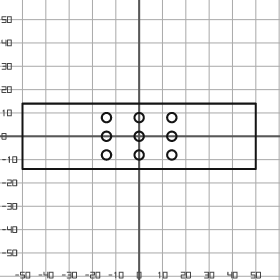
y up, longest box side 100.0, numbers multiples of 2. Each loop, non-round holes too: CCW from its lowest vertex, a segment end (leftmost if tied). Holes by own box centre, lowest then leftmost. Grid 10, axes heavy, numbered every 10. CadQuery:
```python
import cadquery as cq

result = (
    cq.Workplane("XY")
    .moveTo(-50.0, -14.0)
    .lineTo(50.0, -14.0)
    .lineTo(50.0, 14.0)
    .lineTo(-50.0, 14.0)
    .close()
    .moveTo(-14.0, -8.0)
    .circle(2.0)
    .moveTo(0.0, -8.0)
    .circle(2.0)
    .moveTo(14.0, -8.0)
    .circle(2.0)
    .moveTo(-14.0, 0.0)
    .circle(2.0)
    .moveTo(0.0, 0.0)
    .circle(2.0)
    .moveTo(14.0, 0.0)
    .circle(2.0)
    .moveTo(-14.0, 8.0)
    .circle(2.0)
    .moveTo(0.0, 8.0)
    .circle(2.0)
    .moveTo(14.0, 8.0)
    .circle(2.0)
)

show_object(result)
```